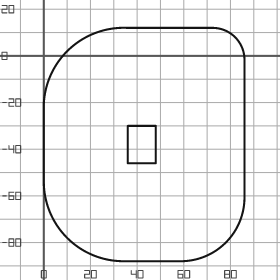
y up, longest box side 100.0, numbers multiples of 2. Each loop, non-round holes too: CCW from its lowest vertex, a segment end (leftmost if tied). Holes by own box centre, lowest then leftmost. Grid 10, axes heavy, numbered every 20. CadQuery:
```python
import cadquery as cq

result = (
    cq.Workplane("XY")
    .moveTo(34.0, -88.0)
    .lineTo(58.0, -88.0)
    .threePointArc((78.0, -80.0), (86.0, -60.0))
    .lineTo(86.0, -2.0)
    .threePointArc((82.0, 8.0), (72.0, 12.0))
    .lineTo(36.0, 12.0)
    .threePointArc((10.0, 2.0), (0.0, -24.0))
    .lineTo(0.0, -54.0)
    .threePointArc((10.0, -78.0), (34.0, -88.0))
    .close()
    .moveTo(36.0, -46.0)
    .lineTo(48.0, -46.0)
    .lineTo(48.0, -30.0)
    .lineTo(36.0, -30.0)
    .close()
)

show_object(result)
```